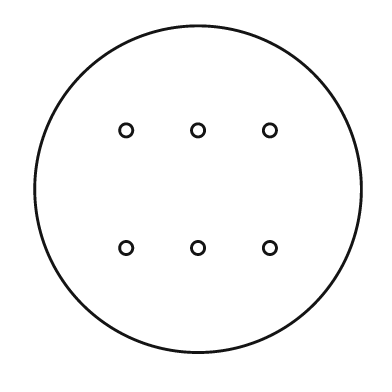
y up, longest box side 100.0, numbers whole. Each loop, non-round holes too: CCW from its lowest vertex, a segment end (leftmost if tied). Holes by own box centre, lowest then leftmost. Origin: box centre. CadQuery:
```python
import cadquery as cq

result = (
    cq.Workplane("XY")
    .moveTo(0.0, 0.0)
    .circle(50.0)
    .moveTo(-22.0, -18.0)
    .circle(2.0)
    .moveTo(0.0, -18.0)
    .circle(2.0)
    .moveTo(22.0, -18.0)
    .circle(2.0)
    .moveTo(-22.0, 18.0)
    .circle(2.0)
    .moveTo(0.0, 18.0)
    .circle(2.0)
    .moveTo(22.0, 18.0)
    .circle(2.0)
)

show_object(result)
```